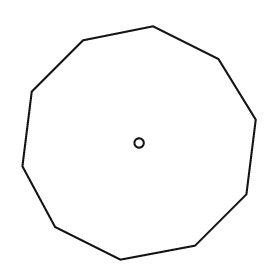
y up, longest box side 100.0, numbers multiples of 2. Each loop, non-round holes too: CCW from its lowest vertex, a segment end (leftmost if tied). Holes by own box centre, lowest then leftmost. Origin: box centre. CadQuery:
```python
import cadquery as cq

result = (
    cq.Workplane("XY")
    .moveTo(-8.0, -50.0)
    .lineTo(24.0, -44.0)
    .lineTo(46.0, -22.0)
    .lineTo(50.0, 10.0)
    .lineTo(34.0, 36.0)
    .lineTo(6.0, 50.0)
    .lineTo(-24.0, 44.0)
    .lineTo(-46.0, 22.0)
    .lineTo(-50.0, -10.0)
    .lineTo(-36.0, -36.0)
    .close()
    .moveTo(0.0, 0.0)
    .circle(2.0)
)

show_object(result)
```